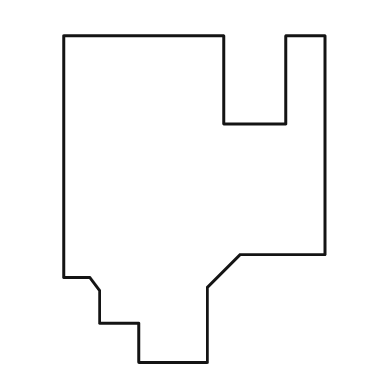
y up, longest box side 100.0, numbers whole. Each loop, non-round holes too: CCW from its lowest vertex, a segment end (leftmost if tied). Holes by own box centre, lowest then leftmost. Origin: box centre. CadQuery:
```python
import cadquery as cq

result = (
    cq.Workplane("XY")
    .moveTo(-17.0, -50.0)
    .lineTo(4.0, -50.0)
    .lineTo(4.0, -27.0)
    .lineTo(14.0, -17.0)
    .lineTo(40.0, -17.0)
    .lineTo(40.0, 50.0)
    .lineTo(28.0, 50.0)
    .lineTo(28.0, 23.0)
    .lineTo(9.0, 23.0)
    .lineTo(9.0, 50.0)
    .lineTo(-40.0, 50.0)
    .lineTo(-40.0, -24.0)
    .lineTo(-32.0, -24.0)
    .lineTo(-29.0, -28.0)
    .lineTo(-29.0, -38.0)
    .lineTo(-17.0, -38.0)
    .close()
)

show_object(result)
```